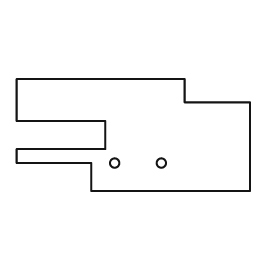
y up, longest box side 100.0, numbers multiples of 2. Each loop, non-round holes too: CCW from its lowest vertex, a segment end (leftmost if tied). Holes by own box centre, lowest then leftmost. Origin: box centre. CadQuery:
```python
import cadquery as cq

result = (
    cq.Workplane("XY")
    .moveTo(-18.0, -24.0)
    .lineTo(50.0, -24.0)
    .lineTo(50.0, 14.0)
    .lineTo(22.0, 14.0)
    .lineTo(22.0, 24.0)
    .lineTo(-50.0, 24.0)
    .lineTo(-50.0, 6.0)
    .lineTo(-12.0, 6.0)
    .lineTo(-12.0, -6.0)
    .lineTo(-50.0, -6.0)
    .lineTo(-50.0, -12.0)
    .lineTo(-18.0, -12.0)
    .close()
    .moveTo(-8.0, -12.0)
    .circle(2.0)
    .moveTo(12.0, -12.0)
    .circle(2.0)
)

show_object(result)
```